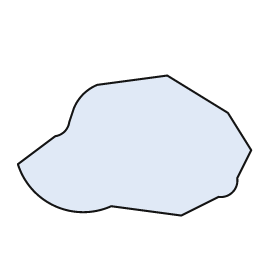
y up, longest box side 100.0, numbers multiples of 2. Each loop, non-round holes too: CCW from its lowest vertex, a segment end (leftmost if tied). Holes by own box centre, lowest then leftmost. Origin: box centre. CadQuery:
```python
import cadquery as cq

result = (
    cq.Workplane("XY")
    .moveTo(20.0, -30.0)
    .lineTo(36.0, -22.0)
    .threePointArc((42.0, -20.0), (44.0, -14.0))
    .lineTo(50.0, -2.0)
    .lineTo(40.0, 14.0)
    .lineTo(14.0, 30.0)
    .lineTo(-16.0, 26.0)
    .threePointArc((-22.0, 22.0), (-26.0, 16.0))
    .lineTo(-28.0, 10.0)
    .threePointArc((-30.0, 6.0), (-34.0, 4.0))
    .lineTo(-50.0, -8.0)
    .threePointArc((-34.0, -26.0), (-10.0, -26.0))
    .close()
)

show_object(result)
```